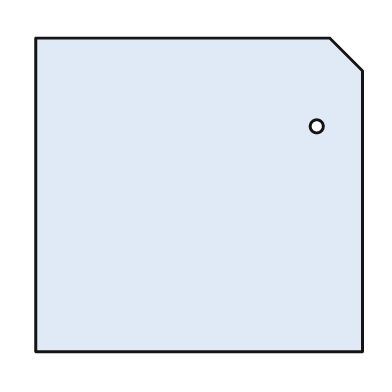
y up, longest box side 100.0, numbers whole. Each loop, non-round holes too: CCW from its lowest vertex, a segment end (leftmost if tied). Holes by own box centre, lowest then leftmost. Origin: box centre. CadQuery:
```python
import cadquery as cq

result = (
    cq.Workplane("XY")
    .moveTo(-50.0, -48.0)
    .lineTo(50.0, -48.0)
    .lineTo(50.0, 38.0)
    .lineTo(40.0, 48.0)
    .lineTo(-50.0, 48.0)
    .close()
    .moveTo(36.0, 21.0)
    .circle(2.0)
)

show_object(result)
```